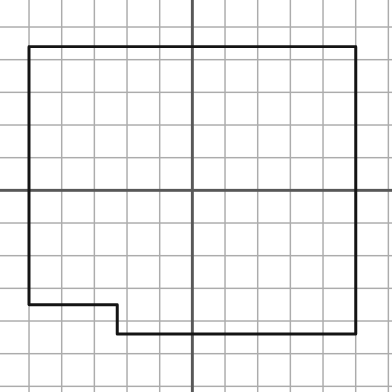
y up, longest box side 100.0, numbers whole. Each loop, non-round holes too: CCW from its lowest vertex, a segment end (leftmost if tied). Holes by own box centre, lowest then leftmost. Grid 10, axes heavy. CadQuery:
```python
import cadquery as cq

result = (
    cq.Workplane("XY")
    .moveTo(-23.0, -44.0)
    .lineTo(50.0, -44.0)
    .lineTo(50.0, 44.0)
    .lineTo(-50.0, 44.0)
    .lineTo(-50.0, -35.0)
    .lineTo(-23.0, -35.0)
    .close()
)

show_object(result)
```